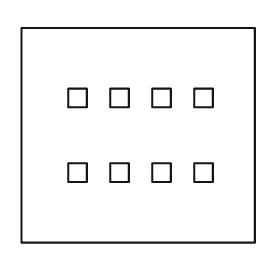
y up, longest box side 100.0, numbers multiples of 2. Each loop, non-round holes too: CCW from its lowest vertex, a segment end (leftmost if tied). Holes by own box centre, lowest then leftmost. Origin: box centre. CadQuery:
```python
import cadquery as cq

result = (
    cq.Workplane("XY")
    .moveTo(-50.0, -46.0)
    .lineTo(50.0, -46.0)
    .lineTo(50.0, 46.0)
    .lineTo(-50.0, 46.0)
    .close()
    .moveTo(-30.0, -20.0)
    .lineTo(-22.0, -20.0)
    .lineTo(-22.0, -12.0)
    .lineTo(-30.0, -12.0)
    .close()
    .moveTo(-12.0, -20.0)
    .lineTo(-4.0, -20.0)
    .lineTo(-4.0, -12.0)
    .lineTo(-12.0, -12.0)
    .close()
    .moveTo(6.0, -20.0)
    .lineTo(14.0, -20.0)
    .lineTo(14.0, -12.0)
    .lineTo(6.0, -12.0)
    .close()
    .moveTo(24.0, -20.0)
    .lineTo(32.0, -20.0)
    .lineTo(32.0, -12.0)
    .lineTo(24.0, -12.0)
    .close()
    .moveTo(-30.0, 12.0)
    .lineTo(-22.0, 12.0)
    .lineTo(-22.0, 20.0)
    .lineTo(-30.0, 20.0)
    .close()
    .moveTo(-12.0, 12.0)
    .lineTo(-4.0, 12.0)
    .lineTo(-4.0, 20.0)
    .lineTo(-12.0, 20.0)
    .close()
    .moveTo(6.0, 12.0)
    .lineTo(14.0, 12.0)
    .lineTo(14.0, 20.0)
    .lineTo(6.0, 20.0)
    .close()
    .moveTo(24.0, 12.0)
    .lineTo(32.0, 12.0)
    .lineTo(32.0, 20.0)
    .lineTo(24.0, 20.0)
    .close()
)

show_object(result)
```